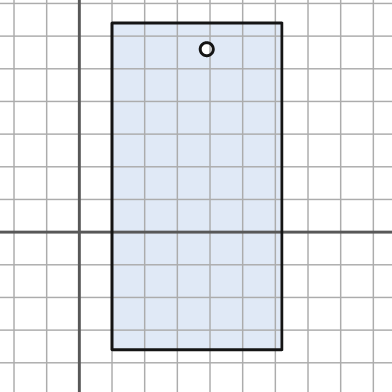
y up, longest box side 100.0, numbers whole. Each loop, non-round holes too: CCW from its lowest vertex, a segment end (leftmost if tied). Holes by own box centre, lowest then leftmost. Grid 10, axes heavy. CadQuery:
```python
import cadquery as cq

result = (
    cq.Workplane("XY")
    .moveTo(10.0, -36.0)
    .lineTo(62.0, -36.0)
    .lineTo(62.0, 64.0)
    .lineTo(10.0, 64.0)
    .close()
    .moveTo(39.0, 56.0)
    .circle(2.0)
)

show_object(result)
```